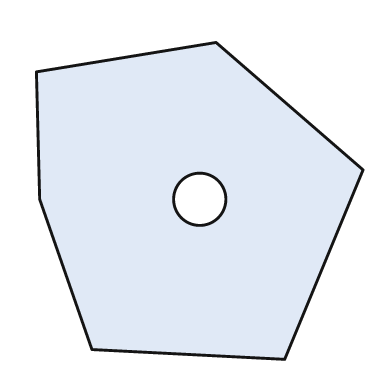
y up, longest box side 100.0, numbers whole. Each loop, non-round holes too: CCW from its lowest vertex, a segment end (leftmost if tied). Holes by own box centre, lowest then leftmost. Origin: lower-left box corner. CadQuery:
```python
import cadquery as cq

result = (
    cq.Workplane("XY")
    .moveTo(76.0, 0.0)
    .lineTo(100.0, 58.0)
    .lineTo(55.0, 97.0)
    .lineTo(0.0, 88.0)
    .lineTo(1.0, 49.0)
    .lineTo(17.0, 3.0)
    .close()
    .moveTo(50.0, 49.0)
    .circle(8.0)
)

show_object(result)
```